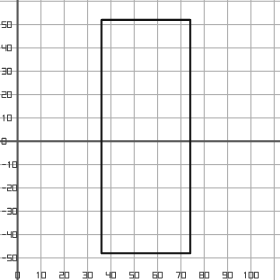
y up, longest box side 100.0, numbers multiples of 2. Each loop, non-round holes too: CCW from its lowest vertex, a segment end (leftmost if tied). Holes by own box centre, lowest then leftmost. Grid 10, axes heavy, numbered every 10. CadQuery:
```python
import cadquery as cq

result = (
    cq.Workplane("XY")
    .moveTo(36.0, -48.0)
    .lineTo(74.0, -48.0)
    .lineTo(74.0, 52.0)
    .lineTo(36.0, 52.0)
    .close()
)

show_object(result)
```